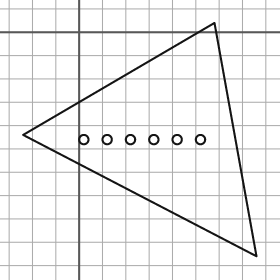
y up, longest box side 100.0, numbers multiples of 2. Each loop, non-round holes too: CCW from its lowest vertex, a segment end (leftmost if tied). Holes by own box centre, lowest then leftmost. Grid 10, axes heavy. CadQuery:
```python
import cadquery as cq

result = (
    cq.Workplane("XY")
    .moveTo(76.0, -96.0)
    .lineTo(58.0, 4.0)
    .lineTo(-24.0, -44.0)
    .close()
    .moveTo(2.0, -46.0)
    .circle(2.0)
    .moveTo(12.0, -46.0)
    .circle(2.0)
    .moveTo(22.0, -46.0)
    .circle(2.0)
    .moveTo(32.0, -46.0)
    .circle(2.0)
    .moveTo(42.0, -46.0)
    .circle(2.0)
    .moveTo(52.0, -46.0)
    .circle(2.0)
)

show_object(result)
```